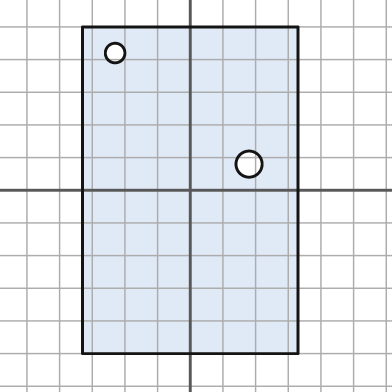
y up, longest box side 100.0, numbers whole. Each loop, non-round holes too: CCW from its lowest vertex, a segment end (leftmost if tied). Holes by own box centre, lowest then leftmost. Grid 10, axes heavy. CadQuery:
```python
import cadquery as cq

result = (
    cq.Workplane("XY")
    .moveTo(-33.0, -50.0)
    .lineTo(33.0, -50.0)
    .lineTo(33.0, 50.0)
    .lineTo(-33.0, 50.0)
    .close()
    .moveTo(18.0, 8.0)
    .circle(4.0)
    .moveTo(-23.0, 42.0)
    .circle(3.0)
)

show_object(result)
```